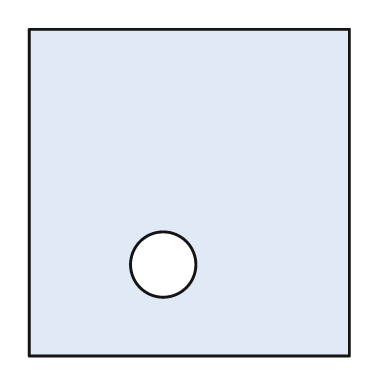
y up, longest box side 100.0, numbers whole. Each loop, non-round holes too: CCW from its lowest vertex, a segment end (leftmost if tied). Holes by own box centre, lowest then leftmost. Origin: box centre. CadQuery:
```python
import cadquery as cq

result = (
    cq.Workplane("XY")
    .moveTo(-49.0, -50.0)
    .lineTo(49.0, -50.0)
    .lineTo(49.0, 50.0)
    .lineTo(-49.0, 50.0)
    .close()
    .moveTo(-8.0, -22.0)
    .circle(10.0)
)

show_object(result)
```